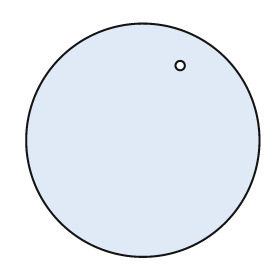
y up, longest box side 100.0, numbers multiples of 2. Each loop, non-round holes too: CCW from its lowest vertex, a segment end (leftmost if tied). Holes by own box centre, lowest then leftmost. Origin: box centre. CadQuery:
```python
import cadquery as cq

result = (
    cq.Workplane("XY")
    .moveTo(0.0, 0.0)
    .circle(50.0)
    .moveTo(16.0, 32.0)
    .circle(2.0)
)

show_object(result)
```